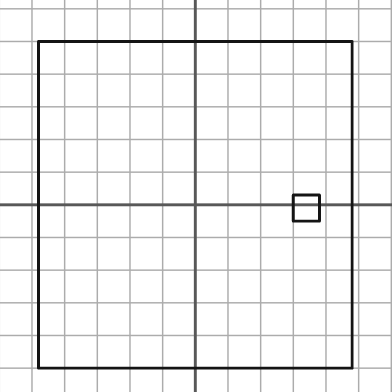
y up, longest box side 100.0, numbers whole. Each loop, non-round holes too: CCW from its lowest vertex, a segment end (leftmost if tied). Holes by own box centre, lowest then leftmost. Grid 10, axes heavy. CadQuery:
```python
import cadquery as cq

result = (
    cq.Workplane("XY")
    .moveTo(-48.0, -50.0)
    .lineTo(48.0, -50.0)
    .lineTo(48.0, 50.0)
    .lineTo(-48.0, 50.0)
    .close()
    .moveTo(30.0, -5.0)
    .lineTo(38.0, -5.0)
    .lineTo(38.0, 3.0)
    .lineTo(30.0, 3.0)
    .close()
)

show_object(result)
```